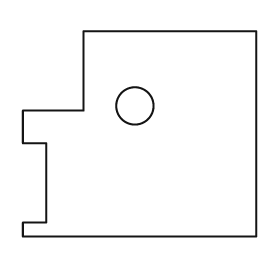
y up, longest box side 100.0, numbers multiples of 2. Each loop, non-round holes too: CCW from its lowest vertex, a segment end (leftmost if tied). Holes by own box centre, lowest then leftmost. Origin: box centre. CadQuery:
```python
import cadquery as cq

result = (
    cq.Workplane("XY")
    .moveTo(-50.0, -44.0)
    .lineTo(50.0, -44.0)
    .lineTo(50.0, 44.0)
    .lineTo(-24.0, 44.0)
    .lineTo(-24.0, 10.0)
    .lineTo(-50.0, 10.0)
    .lineTo(-50.0, -4.0)
    .lineTo(-40.0, -4.0)
    .lineTo(-40.0, -38.0)
    .lineTo(-50.0, -38.0)
    .close()
    .moveTo(-2.0, 12.0)
    .circle(8.0)
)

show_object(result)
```